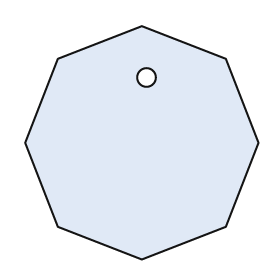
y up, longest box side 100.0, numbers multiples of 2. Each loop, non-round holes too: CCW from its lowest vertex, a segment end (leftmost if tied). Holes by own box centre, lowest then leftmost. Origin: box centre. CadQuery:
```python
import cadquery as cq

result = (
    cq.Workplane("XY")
    .moveTo(0.0, -50.0)
    .lineTo(36.0, -36.0)
    .lineTo(50.0, 0.0)
    .lineTo(36.0, 36.0)
    .lineTo(0.0, 50.0)
    .lineTo(-36.0, 36.0)
    .lineTo(-50.0, 0.0)
    .lineTo(-36.0, -36.0)
    .close()
    .moveTo(2.0, 28.0)
    .circle(4.0)
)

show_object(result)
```